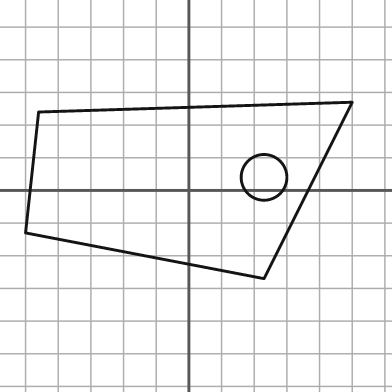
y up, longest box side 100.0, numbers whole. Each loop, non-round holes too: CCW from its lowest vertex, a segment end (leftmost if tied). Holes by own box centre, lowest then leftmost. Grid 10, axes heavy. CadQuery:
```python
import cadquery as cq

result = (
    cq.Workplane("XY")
    .moveTo(23.0, -27.0)
    .lineTo(50.0, 27.0)
    .lineTo(-46.0, 24.0)
    .lineTo(-50.0, -13.0)
    .close()
    .moveTo(23.0, 4.0)
    .circle(7.0)
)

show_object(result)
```